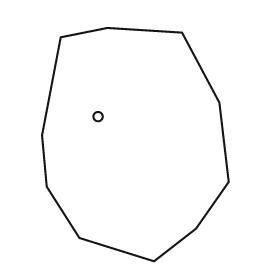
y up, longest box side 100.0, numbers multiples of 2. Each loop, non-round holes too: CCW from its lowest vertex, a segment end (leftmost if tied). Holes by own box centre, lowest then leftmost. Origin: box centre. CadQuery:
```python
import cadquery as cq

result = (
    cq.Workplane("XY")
    .moveTo(8.0, -50.0)
    .lineTo(26.0, -36.0)
    .lineTo(40.0, -16.0)
    .lineTo(36.0, 18.0)
    .lineTo(20.0, 48.0)
    .lineTo(-12.0, 50.0)
    .lineTo(-32.0, 46.0)
    .lineTo(-40.0, 4.0)
    .lineTo(-38.0, -18.0)
    .lineTo(-24.0, -40.0)
    .close()
    .moveTo(-16.0, 12.0)
    .circle(2.0)
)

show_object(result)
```